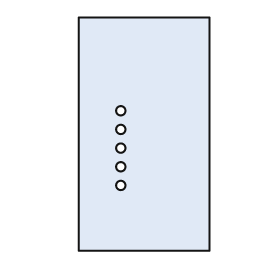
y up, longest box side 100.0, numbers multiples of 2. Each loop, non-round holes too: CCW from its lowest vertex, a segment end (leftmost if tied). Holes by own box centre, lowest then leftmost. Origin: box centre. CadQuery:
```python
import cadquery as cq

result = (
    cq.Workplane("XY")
    .moveTo(-28.0, -50.0)
    .lineTo(28.0, -50.0)
    .lineTo(28.0, 50.0)
    .lineTo(-28.0, 50.0)
    .close()
    .moveTo(-10.0, -22.0)
    .circle(2.0)
    .moveTo(-10.0, -14.0)
    .circle(2.0)
    .moveTo(-10.0, -6.0)
    .circle(2.0)
    .moveTo(-10.0, 2.0)
    .circle(2.0)
    .moveTo(-10.0, 10.0)
    .circle(2.0)
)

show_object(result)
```